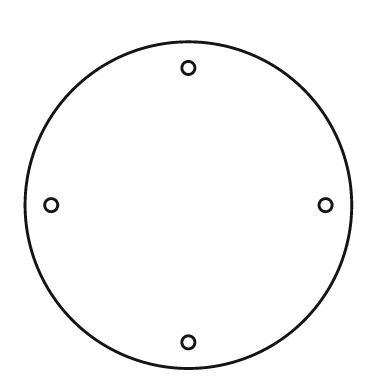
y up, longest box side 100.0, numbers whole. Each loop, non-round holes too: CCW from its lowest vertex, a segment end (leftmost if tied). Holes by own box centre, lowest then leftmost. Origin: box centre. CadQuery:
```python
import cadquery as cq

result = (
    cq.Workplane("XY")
    .moveTo(0.0, 0.0)
    .circle(50.0)
    .moveTo(0.0, -42.0)
    .circle(2.0)
    .moveTo(-42.0, 0.0)
    .circle(2.0)
    .moveTo(42.0, 0.0)
    .circle(2.0)
    .moveTo(0.0, 42.0)
    .circle(2.0)
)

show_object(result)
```